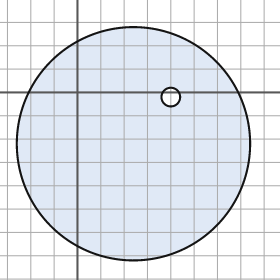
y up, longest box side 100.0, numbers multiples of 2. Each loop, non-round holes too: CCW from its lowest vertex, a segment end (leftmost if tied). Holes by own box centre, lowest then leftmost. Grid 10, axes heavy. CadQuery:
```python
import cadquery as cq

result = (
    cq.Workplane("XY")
    .moveTo(24.0, -22.0)
    .circle(50.0)
    .moveTo(40.0, -2.0)
    .circle(4.0)
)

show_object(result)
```